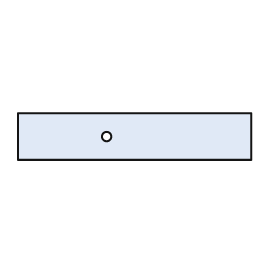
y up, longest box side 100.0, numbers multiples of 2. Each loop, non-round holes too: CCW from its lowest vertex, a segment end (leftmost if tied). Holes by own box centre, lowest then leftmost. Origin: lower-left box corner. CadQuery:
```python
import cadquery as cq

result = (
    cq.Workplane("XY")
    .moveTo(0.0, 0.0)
    .lineTo(100.0, 0.0)
    .lineTo(100.0, 20.0)
    .lineTo(0.0, 20.0)
    .close()
    .moveTo(38.0, 10.0)
    .circle(2.0)
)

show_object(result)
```